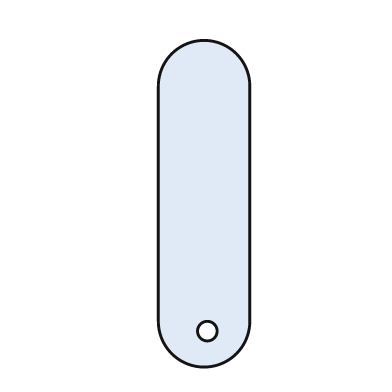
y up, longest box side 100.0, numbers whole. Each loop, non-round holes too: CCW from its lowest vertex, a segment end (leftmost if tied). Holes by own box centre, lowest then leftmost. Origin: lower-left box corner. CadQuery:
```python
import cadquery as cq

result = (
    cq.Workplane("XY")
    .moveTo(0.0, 14.0)
    .threePointArc((14.0, 0.0), (28.0, 14.0))
    .lineTo(28.0, 86.0)
    .threePointArc((14.0, 100.0), (0.0, 86.0))
    .close()
    .moveTo(15.0, 11.0)
    .circle(3.0)
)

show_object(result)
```